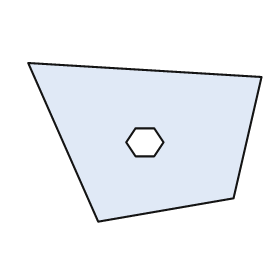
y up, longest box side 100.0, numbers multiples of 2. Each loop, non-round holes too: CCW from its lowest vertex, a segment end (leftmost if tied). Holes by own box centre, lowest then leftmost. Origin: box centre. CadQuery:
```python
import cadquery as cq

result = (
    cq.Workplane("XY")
    .moveTo(-20.0, -34.0)
    .lineTo(38.0, -24.0)
    .lineTo(50.0, 28.0)
    .lineTo(-50.0, 34.0)
    .close()
    .moveTo(-4.0, -6.0)
    .lineTo(4.0, -6.0)
    .lineTo(8.0, 0.0)
    .lineTo(4.0, 6.0)
    .lineTo(-4.0, 6.0)
    .lineTo(-8.0, 0.0)
    .close()
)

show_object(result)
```